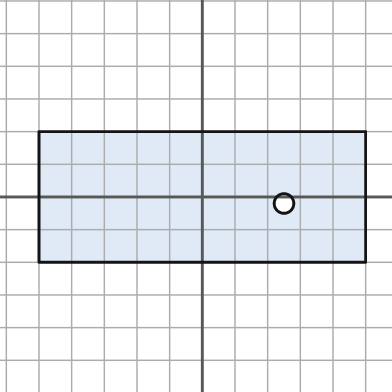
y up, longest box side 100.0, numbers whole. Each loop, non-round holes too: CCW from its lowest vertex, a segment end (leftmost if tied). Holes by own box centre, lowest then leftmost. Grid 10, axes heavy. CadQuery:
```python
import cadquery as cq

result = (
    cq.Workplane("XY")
    .moveTo(-50.0, -20.0)
    .lineTo(50.0, -20.0)
    .lineTo(50.0, 20.0)
    .lineTo(-50.0, 20.0)
    .close()
    .moveTo(25.0, -2.0)
    .circle(3.0)
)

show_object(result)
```